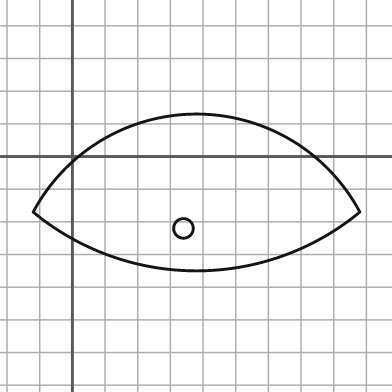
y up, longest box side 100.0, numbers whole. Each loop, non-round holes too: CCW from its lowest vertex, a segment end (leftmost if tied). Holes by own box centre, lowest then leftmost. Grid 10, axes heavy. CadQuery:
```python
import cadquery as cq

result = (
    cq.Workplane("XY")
    .moveTo(-12.0, -17.0)
    .threePointArc((38.0, -35.0), (88.0, -17.0))
    .threePointArc((38.0, 13.0), (-12.0, -17.0))
    .close()
    .moveTo(34.0, -22.0)
    .circle(3.0)
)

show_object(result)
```